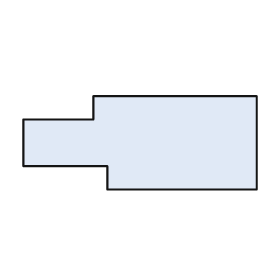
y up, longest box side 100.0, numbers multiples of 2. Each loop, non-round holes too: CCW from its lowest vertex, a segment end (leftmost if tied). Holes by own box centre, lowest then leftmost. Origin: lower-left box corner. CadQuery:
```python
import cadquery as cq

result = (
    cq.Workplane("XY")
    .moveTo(36.0, 0.0)
    .lineTo(100.0, 0.0)
    .lineTo(100.0, 40.0)
    .lineTo(30.0, 40.0)
    .lineTo(30.0, 30.0)
    .lineTo(0.0, 30.0)
    .lineTo(0.0, 10.0)
    .lineTo(36.0, 10.0)
    .close()
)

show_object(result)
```